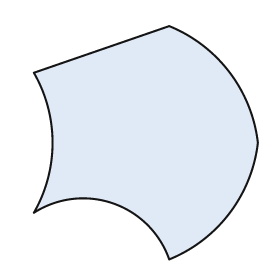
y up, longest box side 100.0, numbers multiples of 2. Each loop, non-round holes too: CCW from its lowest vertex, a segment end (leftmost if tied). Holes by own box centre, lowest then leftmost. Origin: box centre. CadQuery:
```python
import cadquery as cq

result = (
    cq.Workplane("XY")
    .moveTo(10.0, -50.0)
    .threePointArc((36.0, -30.0), (48.0, 0.0))
    .threePointArc((36.0, 30.0), (10.0, 50.0))
    .lineTo(-48.0, 30.0)
    .threePointArc((-40.0, 0.0), (-48.0, -30.0))
    .threePointArc((-14.0, -26.0), (10.0, -50.0))
    .close()
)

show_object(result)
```